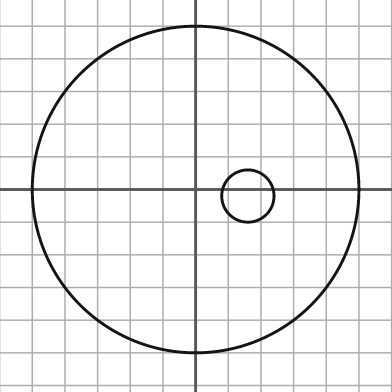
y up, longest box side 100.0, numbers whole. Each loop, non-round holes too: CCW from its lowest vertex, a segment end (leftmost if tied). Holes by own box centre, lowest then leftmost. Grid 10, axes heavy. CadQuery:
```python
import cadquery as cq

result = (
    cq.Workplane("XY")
    .moveTo(0.0, 0.0)
    .circle(50.0)
    .moveTo(16.0, -2.0)
    .circle(8.0)
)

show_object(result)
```